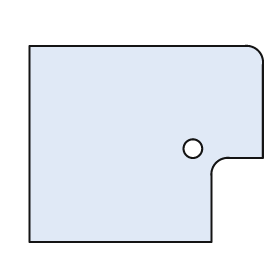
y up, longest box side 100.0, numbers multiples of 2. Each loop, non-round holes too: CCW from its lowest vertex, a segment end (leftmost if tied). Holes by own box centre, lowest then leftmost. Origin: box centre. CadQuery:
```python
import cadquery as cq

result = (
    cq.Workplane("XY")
    .moveTo(-50.0, -42.0)
    .lineTo(28.0, -42.0)
    .lineTo(28.0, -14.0)
    .threePointArc((30.0, -8.0), (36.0, -6.0))
    .lineTo(50.0, -6.0)
    .lineTo(50.0, 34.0)
    .threePointArc((48.0, 40.0), (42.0, 42.0))
    .lineTo(-50.0, 42.0)
    .close()
    .moveTo(20.0, -2.0)
    .circle(4.0)
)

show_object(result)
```